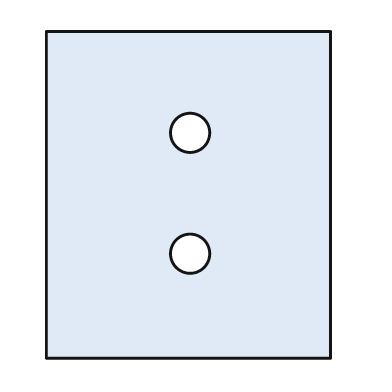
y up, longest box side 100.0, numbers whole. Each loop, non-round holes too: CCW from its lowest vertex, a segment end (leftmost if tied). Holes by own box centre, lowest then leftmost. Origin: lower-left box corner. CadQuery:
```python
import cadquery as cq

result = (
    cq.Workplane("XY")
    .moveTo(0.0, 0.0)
    .lineTo(87.0, 0.0)
    .lineTo(87.0, 100.0)
    .lineTo(0.0, 100.0)
    .close()
    .moveTo(44.0, 32.0)
    .circle(6.0)
    .moveTo(44.0, 69.0)
    .circle(6.0)
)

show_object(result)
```